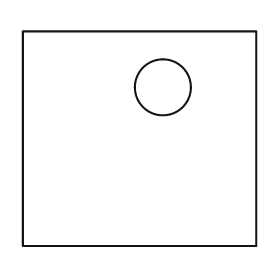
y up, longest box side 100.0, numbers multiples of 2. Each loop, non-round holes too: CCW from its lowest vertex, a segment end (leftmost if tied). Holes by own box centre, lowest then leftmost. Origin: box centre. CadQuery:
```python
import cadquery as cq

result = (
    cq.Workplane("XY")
    .moveTo(-50.0, -46.0)
    .lineTo(50.0, -46.0)
    .lineTo(50.0, 46.0)
    .lineTo(-50.0, 46.0)
    .close()
    .moveTo(10.0, 22.0)
    .circle(12.0)
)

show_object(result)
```